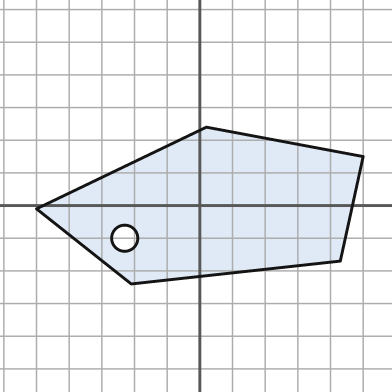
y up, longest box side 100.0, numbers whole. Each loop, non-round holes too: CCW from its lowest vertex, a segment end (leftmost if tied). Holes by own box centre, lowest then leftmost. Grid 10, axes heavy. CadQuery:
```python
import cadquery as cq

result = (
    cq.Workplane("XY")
    .moveTo(-21.0, -24.0)
    .lineTo(43.0, -17.0)
    .lineTo(50.0, 15.0)
    .lineTo(2.0, 24.0)
    .lineTo(-50.0, -1.0)
    .close()
    .moveTo(-23.0, -10.0)
    .circle(4.0)
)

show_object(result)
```